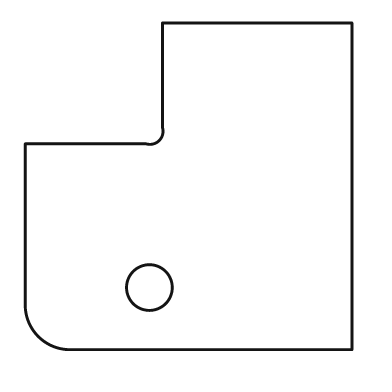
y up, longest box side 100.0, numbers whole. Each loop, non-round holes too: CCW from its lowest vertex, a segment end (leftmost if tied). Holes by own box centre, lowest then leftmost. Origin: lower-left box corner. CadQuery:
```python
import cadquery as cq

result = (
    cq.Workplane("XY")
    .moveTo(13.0, 0.0)
    .lineTo(100.0, 0.0)
    .lineTo(100.0, 100.0)
    .lineTo(42.0, 100.0)
    .lineTo(42.0, 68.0)
    .threePointArc((41.0, 64.0), (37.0, 63.0))
    .lineTo(0.0, 63.0)
    .lineTo(0.0, 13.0)
    .threePointArc((4.0, 4.0), (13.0, 0.0))
    .close()
    .moveTo(38.0, 19.0)
    .circle(7.0)
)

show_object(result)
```